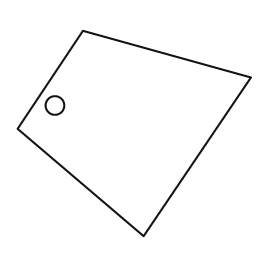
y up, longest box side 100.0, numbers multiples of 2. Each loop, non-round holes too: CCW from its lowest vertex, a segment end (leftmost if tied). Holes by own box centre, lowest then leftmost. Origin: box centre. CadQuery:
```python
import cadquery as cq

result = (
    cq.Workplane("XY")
    .moveTo(4.0, -44.0)
    .lineTo(50.0, 24.0)
    .lineTo(-22.0, 44.0)
    .lineTo(-50.0, 2.0)
    .close()
    .moveTo(-34.0, 12.0)
    .circle(4.0)
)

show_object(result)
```